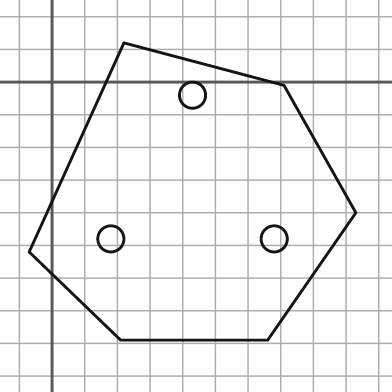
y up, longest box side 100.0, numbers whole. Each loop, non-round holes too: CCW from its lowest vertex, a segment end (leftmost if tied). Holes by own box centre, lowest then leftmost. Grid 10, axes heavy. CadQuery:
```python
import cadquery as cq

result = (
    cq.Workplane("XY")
    .moveTo(21.0, -79.0)
    .lineTo(66.0, -79.0)
    .lineTo(93.0, -40.0)
    .lineTo(71.0, -1.0)
    .lineTo(22.0, 12.0)
    .lineTo(-7.0, -52.0)
    .close()
    .moveTo(18.0, -48.0)
    .circle(4.0)
    .moveTo(68.0, -48.0)
    .circle(4.0)
    .moveTo(43.0, -4.0)
    .circle(4.0)
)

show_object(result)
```